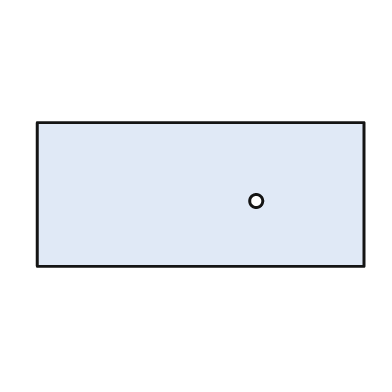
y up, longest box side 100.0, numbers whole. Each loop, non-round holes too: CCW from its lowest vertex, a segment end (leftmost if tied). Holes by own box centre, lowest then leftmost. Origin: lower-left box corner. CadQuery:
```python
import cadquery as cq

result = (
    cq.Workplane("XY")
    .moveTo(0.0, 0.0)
    .lineTo(100.0, 0.0)
    .lineTo(100.0, 44.0)
    .lineTo(0.0, 44.0)
    .close()
    .moveTo(67.0, 20.0)
    .circle(2.0)
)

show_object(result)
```